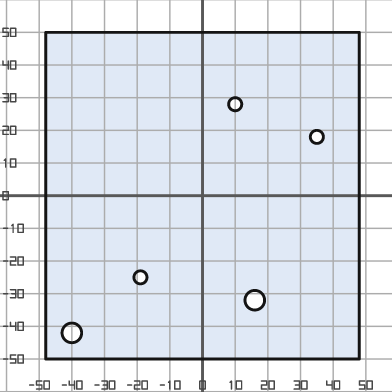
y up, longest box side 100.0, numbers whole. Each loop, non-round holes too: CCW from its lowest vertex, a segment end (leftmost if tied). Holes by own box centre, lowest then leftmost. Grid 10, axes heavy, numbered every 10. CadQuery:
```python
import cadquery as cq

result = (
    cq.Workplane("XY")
    .moveTo(-48.0, -50.0)
    .lineTo(48.0, -50.0)
    .lineTo(48.0, 50.0)
    .lineTo(-48.0, 50.0)
    .close()
    .moveTo(-40.0, -42.0)
    .circle(3.0)
    .moveTo(16.0, -32.0)
    .circle(3.0)
    .moveTo(-19.0, -25.0)
    .circle(2.0)
    .moveTo(35.0, 18.0)
    .circle(2.0)
    .moveTo(10.0, 28.0)
    .circle(2.0)
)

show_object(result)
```